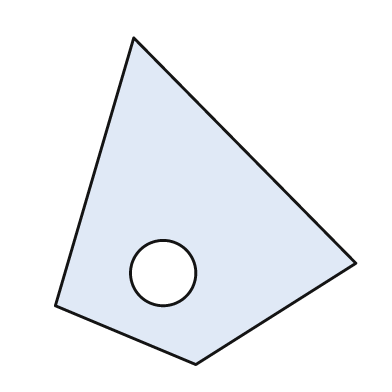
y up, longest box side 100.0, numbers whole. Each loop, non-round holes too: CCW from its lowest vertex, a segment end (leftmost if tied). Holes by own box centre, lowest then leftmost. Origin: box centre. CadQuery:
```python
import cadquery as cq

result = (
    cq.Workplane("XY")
    .moveTo(-3.0, -50.0)
    .lineTo(46.0, -19.0)
    .lineTo(-22.0, 50.0)
    .lineTo(-46.0, -32.0)
    .close()
    .moveTo(-13.0, -22.0)
    .circle(10.0)
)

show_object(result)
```